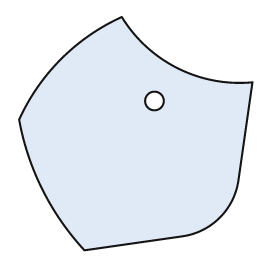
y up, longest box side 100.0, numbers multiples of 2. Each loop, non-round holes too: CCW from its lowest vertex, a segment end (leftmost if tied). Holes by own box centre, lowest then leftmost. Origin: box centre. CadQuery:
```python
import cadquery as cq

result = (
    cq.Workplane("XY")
    .moveTo(-22.0, -50.0)
    .lineTo(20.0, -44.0)
    .threePointArc((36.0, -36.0), (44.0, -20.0))
    .lineTo(50.0, 22.0)
    .threePointArc((18.0, 28.0), (-6.0, 50.0))
    .threePointArc((-32.0, 32.0), (-50.0, 6.0))
    .threePointArc((-40.0, -24.0), (-22.0, -50.0))
    .close()
    .moveTo(8.0, 14.0)
    .circle(4.0)
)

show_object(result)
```